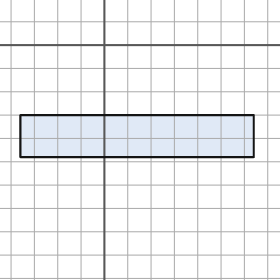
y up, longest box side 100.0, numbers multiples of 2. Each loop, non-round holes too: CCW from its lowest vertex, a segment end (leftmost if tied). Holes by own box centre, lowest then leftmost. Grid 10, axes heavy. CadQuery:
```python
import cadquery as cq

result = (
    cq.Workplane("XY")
    .moveTo(-36.0, -48.0)
    .lineTo(64.0, -48.0)
    .lineTo(64.0, -30.0)
    .lineTo(-36.0, -30.0)
    .close()
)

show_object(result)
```